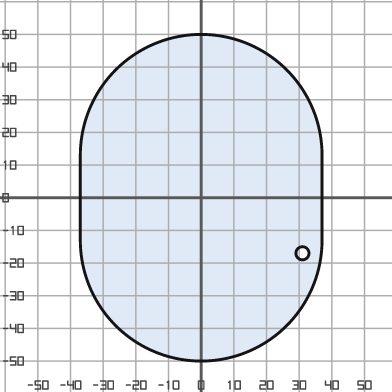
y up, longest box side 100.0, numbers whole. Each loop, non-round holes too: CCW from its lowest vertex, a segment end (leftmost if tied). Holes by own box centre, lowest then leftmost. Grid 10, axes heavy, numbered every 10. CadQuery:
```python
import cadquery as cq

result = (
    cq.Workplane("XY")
    .moveTo(-37.0, -13.0)
    .threePointArc((0.0, -50.0), (37.0, -13.0))
    .lineTo(37.0, 13.0)
    .threePointArc((0.0, 50.0), (-37.0, 13.0))
    .close()
    .moveTo(31.0, -17.0)
    .circle(2.0)
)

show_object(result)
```